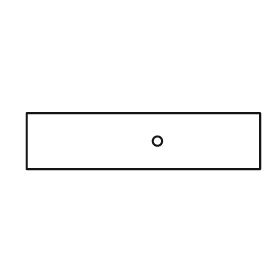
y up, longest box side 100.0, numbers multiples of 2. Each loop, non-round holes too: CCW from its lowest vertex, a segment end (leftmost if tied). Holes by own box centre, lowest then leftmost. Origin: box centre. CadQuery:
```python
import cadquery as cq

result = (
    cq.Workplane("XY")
    .moveTo(-50.0, -12.0)
    .lineTo(50.0, -12.0)
    .lineTo(50.0, 12.0)
    .lineTo(-50.0, 12.0)
    .close()
    .moveTo(6.0, 0.0)
    .circle(2.0)
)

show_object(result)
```